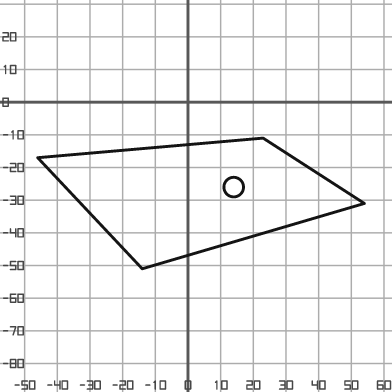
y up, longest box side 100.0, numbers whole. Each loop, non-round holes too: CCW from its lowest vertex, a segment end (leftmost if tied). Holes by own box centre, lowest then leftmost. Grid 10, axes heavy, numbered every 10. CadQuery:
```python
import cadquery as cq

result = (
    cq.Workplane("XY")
    .moveTo(-14.0, -51.0)
    .lineTo(54.0, -31.0)
    .lineTo(23.0, -11.0)
    .lineTo(-46.0, -17.0)
    .close()
    .moveTo(14.0, -26.0)
    .circle(3.0)
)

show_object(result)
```